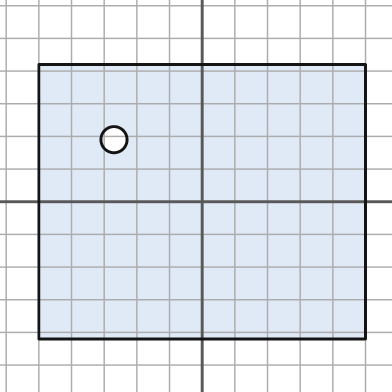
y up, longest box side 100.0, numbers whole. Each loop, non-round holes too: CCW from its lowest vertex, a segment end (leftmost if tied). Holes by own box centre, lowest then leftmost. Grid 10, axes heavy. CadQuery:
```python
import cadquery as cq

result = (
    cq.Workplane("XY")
    .moveTo(-50.0, -42.0)
    .lineTo(50.0, -42.0)
    .lineTo(50.0, 42.0)
    .lineTo(-50.0, 42.0)
    .close()
    .moveTo(-27.0, 19.0)
    .circle(4.0)
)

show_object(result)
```